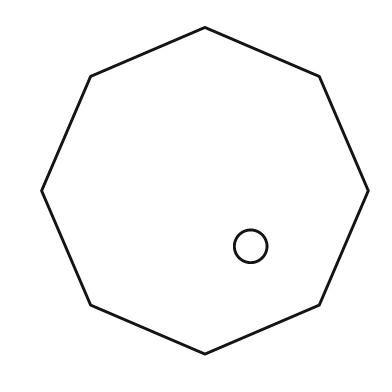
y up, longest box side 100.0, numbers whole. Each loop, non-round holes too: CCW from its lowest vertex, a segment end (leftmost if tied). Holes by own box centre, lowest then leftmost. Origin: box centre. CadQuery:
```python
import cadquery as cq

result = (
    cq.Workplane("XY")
    .moveTo(0.0, -50.0)
    .lineTo(35.0, -35.0)
    .lineTo(50.0, 0.0)
    .lineTo(35.0, 35.0)
    .lineTo(0.0, 50.0)
    .lineTo(-35.0, 35.0)
    .lineTo(-50.0, 0.0)
    .lineTo(-35.0, -35.0)
    .close()
    .moveTo(14.0, -17.0)
    .circle(5.0)
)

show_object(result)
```